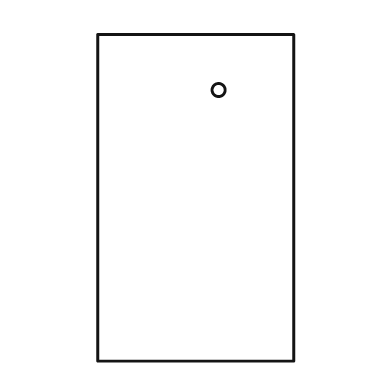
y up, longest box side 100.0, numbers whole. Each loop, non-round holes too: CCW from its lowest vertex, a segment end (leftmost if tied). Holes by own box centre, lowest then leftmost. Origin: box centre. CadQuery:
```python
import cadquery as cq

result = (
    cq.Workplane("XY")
    .moveTo(-30.0, -50.0)
    .lineTo(30.0, -50.0)
    .lineTo(30.0, 50.0)
    .lineTo(-30.0, 50.0)
    .close()
    .moveTo(7.0, 33.0)
    .circle(2.0)
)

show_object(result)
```